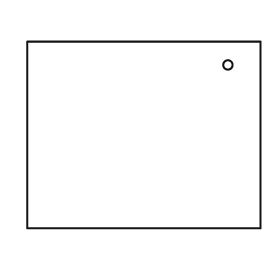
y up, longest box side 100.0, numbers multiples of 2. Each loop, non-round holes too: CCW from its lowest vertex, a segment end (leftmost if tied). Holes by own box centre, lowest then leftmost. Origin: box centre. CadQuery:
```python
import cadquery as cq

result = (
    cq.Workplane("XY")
    .moveTo(-50.0, -40.0)
    .lineTo(50.0, -40.0)
    .lineTo(50.0, 40.0)
    .lineTo(-50.0, 40.0)
    .close()
    .moveTo(36.0, 30.0)
    .circle(2.0)
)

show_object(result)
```